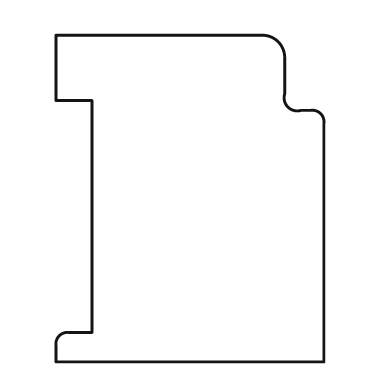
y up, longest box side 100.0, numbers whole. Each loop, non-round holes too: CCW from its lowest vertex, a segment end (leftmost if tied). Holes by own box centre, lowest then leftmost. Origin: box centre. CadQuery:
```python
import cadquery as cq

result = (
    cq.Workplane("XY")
    .moveTo(-41.0, -50.0)
    .lineTo(41.0, -50.0)
    .lineTo(41.0, 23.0)
    .threePointArc((40.0, 26.0), (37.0, 27.0))
    .lineTo(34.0, 27.0)
    .threePointArc((30.0, 28.0), (29.0, 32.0))
    .lineTo(29.0, 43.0)
    .threePointArc((27.0, 48.0), (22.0, 50.0))
    .lineTo(-41.0, 50.0)
    .lineTo(-41.0, 30.0)
    .lineTo(-30.0, 30.0)
    .lineTo(-30.0, -41.0)
    .lineTo(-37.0, -41.0)
    .threePointArc((-40.0, -42.0), (-41.0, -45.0))
    .close()
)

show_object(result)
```